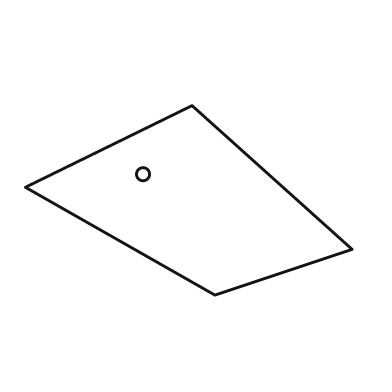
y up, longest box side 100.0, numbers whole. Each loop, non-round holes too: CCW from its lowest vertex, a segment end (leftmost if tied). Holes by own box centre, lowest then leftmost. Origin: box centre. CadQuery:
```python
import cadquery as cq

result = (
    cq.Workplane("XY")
    .moveTo(8.0, -29.0)
    .lineTo(50.0, -15.0)
    .lineTo(1.0, 29.0)
    .lineTo(-50.0, 4.0)
    .close()
    .moveTo(-14.0, 8.0)
    .circle(2.0)
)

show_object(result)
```